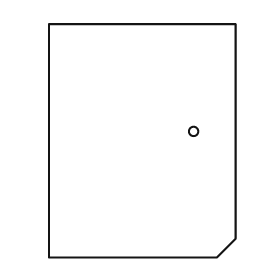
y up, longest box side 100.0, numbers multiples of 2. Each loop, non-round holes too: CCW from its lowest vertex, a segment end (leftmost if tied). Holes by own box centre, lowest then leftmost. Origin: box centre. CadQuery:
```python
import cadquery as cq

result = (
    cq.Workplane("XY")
    .moveTo(-40.0, -50.0)
    .lineTo(32.0, -50.0)
    .lineTo(40.0, -42.0)
    .lineTo(40.0, 50.0)
    .lineTo(-40.0, 50.0)
    .close()
    .moveTo(22.0, 4.0)
    .circle(2.0)
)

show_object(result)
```